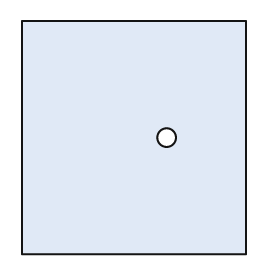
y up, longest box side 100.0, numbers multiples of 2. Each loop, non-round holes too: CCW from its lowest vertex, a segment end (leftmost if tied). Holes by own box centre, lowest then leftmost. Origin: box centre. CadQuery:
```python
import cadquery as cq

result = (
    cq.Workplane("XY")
    .moveTo(-48.0, -50.0)
    .lineTo(48.0, -50.0)
    .lineTo(48.0, 50.0)
    .lineTo(-48.0, 50.0)
    .close()
    .moveTo(14.0, 0.0)
    .circle(4.0)
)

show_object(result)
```